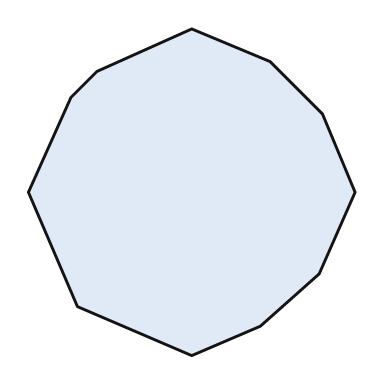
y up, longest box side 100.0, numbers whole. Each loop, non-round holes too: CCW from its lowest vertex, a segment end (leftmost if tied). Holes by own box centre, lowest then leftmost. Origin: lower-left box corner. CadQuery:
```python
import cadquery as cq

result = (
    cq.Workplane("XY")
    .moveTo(50.0, 0.0)
    .lineTo(71.0, 9.0)
    .lineTo(89.0, 25.0)
    .lineTo(100.0, 50.0)
    .lineTo(90.0, 74.0)
    .lineTo(74.0, 90.0)
    .lineTo(50.0, 100.0)
    .lineTo(21.0, 87.0)
    .lineTo(13.0, 79.0)
    .lineTo(0.0, 50.0)
    .lineTo(15.0, 15.0)
    .close()
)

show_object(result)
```